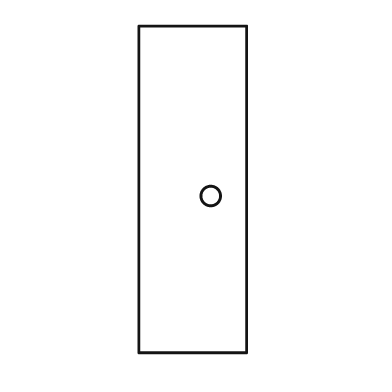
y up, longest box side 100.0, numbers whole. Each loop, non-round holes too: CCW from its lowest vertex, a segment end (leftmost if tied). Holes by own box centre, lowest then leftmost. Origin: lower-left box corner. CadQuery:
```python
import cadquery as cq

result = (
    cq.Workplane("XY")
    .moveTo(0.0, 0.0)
    .lineTo(33.0, 0.0)
    .lineTo(33.0, 100.0)
    .lineTo(0.0, 100.0)
    .close()
    .moveTo(22.0, 48.0)
    .circle(3.0)
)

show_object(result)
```